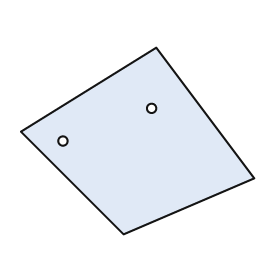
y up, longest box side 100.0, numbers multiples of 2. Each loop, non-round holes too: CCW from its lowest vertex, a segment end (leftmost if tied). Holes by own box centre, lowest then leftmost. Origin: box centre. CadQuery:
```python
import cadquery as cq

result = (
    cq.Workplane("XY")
    .moveTo(-6.0, -40.0)
    .lineTo(50.0, -16.0)
    .lineTo(8.0, 40.0)
    .lineTo(-50.0, 4.0)
    .close()
    .moveTo(-32.0, 0.0)
    .circle(2.0)
    .moveTo(6.0, 14.0)
    .circle(2.0)
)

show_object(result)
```